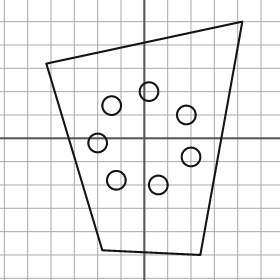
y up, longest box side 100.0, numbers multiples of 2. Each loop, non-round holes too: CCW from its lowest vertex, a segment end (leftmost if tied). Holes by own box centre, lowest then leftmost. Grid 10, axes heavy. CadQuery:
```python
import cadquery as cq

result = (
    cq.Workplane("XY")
    .moveTo(24.0, -50.0)
    .lineTo(42.0, 50.0)
    .lineTo(-42.0, 32.0)
    .lineTo(-18.0, -48.0)
    .close()
    .moveTo(6.0, -20.0)
    .circle(4.0)
    .moveTo(-12.0, -18.0)
    .circle(4.0)
    .moveTo(20.0, -8.0)
    .circle(4.0)
    .moveTo(-20.0, -2.0)
    .circle(4.0)
    .moveTo(18.0, 10.0)
    .circle(4.0)
    .moveTo(-14.0, 14.0)
    .circle(4.0)
    .moveTo(2.0, 20.0)
    .circle(4.0)
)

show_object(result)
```